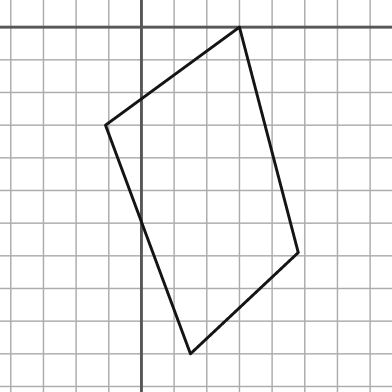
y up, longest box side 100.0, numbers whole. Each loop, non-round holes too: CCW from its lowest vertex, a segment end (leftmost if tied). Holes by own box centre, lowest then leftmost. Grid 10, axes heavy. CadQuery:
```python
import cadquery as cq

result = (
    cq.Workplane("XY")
    .moveTo(15.0, -100.0)
    .lineTo(48.0, -69.0)
    .lineTo(30.0, 0.0)
    .lineTo(-11.0, -30.0)
    .close()
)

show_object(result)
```